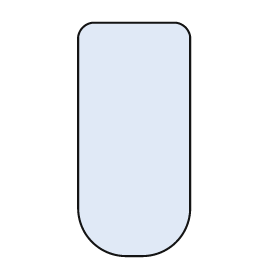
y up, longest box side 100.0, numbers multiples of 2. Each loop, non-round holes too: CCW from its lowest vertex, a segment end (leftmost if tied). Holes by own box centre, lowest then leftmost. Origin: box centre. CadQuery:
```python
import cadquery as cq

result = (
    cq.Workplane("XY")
    .moveTo(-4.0, -50.0)
    .lineTo(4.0, -50.0)
    .threePointArc((18.0, -44.0), (24.0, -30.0))
    .lineTo(24.0, 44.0)
    .threePointArc((22.0, 48.0), (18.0, 50.0))
    .lineTo(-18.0, 50.0)
    .threePointArc((-22.0, 48.0), (-24.0, 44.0))
    .lineTo(-24.0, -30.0)
    .threePointArc((-18.0, -44.0), (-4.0, -50.0))
    .close()
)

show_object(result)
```